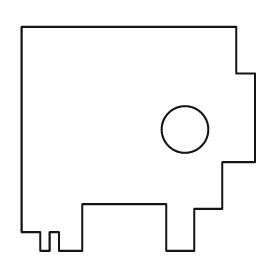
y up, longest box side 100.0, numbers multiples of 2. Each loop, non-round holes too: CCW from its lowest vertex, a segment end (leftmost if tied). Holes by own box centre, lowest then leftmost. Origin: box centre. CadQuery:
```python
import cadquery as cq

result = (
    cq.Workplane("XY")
    .moveTo(-42.0, -48.0)
    .lineTo(-38.0, -48.0)
    .lineTo(-38.0, -40.0)
    .lineTo(-34.0, -40.0)
    .lineTo(-34.0, -48.0)
    .lineTo(-24.0, -48.0)
    .lineTo(-24.0, -28.0)
    .lineTo(12.0, -28.0)
    .lineTo(12.0, -48.0)
    .lineTo(24.0, -48.0)
    .lineTo(24.0, -30.0)
    .lineTo(36.0, -30.0)
    .lineTo(36.0, -10.0)
    .lineTo(50.0, -10.0)
    .lineTo(50.0, 28.0)
    .lineTo(42.0, 28.0)
    .lineTo(42.0, 48.0)
    .lineTo(-50.0, 48.0)
    .lineTo(-50.0, -40.0)
    .lineTo(-42.0, -40.0)
    .close()
    .moveTo(20.0, 4.0)
    .circle(10.0)
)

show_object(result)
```